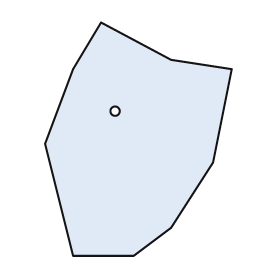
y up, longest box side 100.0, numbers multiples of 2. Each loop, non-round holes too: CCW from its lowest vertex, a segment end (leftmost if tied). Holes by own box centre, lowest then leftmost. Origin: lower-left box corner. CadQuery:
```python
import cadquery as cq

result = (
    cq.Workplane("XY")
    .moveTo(12.0, 0.0)
    .lineTo(38.0, 0.0)
    .lineTo(54.0, 12.0)
    .lineTo(72.0, 40.0)
    .lineTo(80.0, 80.0)
    .lineTo(54.0, 84.0)
    .lineTo(24.0, 100.0)
    .lineTo(12.0, 80.0)
    .lineTo(0.0, 48.0)
    .close()
    .moveTo(30.0, 62.0)
    .circle(2.0)
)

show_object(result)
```